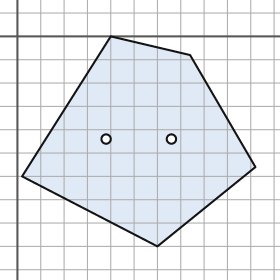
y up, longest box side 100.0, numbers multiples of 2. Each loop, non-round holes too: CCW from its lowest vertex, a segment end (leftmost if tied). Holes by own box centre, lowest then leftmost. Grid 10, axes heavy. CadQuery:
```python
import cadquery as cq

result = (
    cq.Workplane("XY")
    .moveTo(60.0, -90.0)
    .lineTo(102.0, -56.0)
    .lineTo(74.0, -8.0)
    .lineTo(40.0, 0.0)
    .lineTo(2.0, -60.0)
    .close()
    .moveTo(38.0, -44.0)
    .circle(2.0)
    .moveTo(66.0, -44.0)
    .circle(2.0)
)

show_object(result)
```